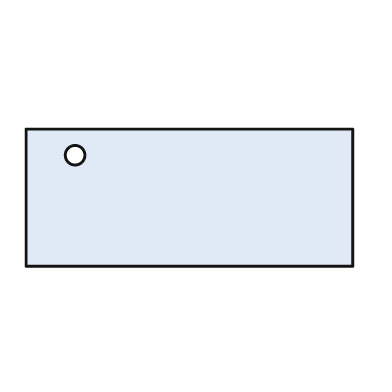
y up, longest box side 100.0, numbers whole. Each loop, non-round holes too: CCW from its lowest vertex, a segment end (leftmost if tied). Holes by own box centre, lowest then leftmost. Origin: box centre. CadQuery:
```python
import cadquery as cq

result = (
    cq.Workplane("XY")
    .moveTo(-50.0, -21.0)
    .lineTo(50.0, -21.0)
    .lineTo(50.0, 21.0)
    .lineTo(-50.0, 21.0)
    .close()
    .moveTo(-35.0, 13.0)
    .circle(3.0)
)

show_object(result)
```